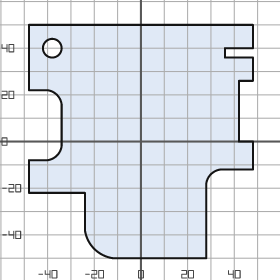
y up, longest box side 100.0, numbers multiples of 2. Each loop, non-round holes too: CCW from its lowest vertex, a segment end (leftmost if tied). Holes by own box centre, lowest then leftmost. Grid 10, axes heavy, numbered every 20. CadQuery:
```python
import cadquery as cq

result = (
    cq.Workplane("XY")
    .moveTo(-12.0, -50.0)
    .lineTo(28.0, -50.0)
    .lineTo(28.0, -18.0)
    .threePointArc((30.0, -14.0), (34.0, -12.0))
    .lineTo(48.0, -12.0)
    .lineTo(48.0, 0.0)
    .lineTo(42.0, 0.0)
    .lineTo(42.0, 26.0)
    .lineTo(48.0, 26.0)
    .lineTo(48.0, 36.0)
    .lineTo(36.0, 36.0)
    .lineTo(36.0, 40.0)
    .lineTo(48.0, 40.0)
    .lineTo(48.0, 50.0)
    .lineTo(-48.0, 50.0)
    .lineTo(-48.0, 22.0)
    .lineTo(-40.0, 22.0)
    .threePointArc((-36.0, 20.0), (-34.0, 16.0))
    .lineTo(-34.0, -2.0)
    .threePointArc((-36.0, -6.0), (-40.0, -8.0))
    .lineTo(-48.0, -8.0)
    .lineTo(-48.0, -22.0)
    .lineTo(-24.0, -22.0)
    .lineTo(-24.0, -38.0)
    .threePointArc((-20.0, -46.0), (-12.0, -50.0))
    .close()
    .moveTo(-38.0, 40.0)
    .circle(4.0)
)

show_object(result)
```